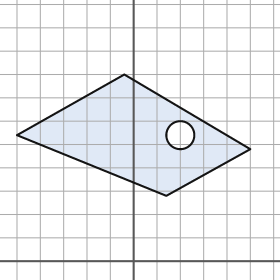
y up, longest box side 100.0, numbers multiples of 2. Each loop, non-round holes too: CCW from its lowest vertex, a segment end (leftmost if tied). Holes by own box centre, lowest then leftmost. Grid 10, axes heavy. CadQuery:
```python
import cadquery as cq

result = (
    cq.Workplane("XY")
    .moveTo(14.0, 28.0)
    .lineTo(50.0, 48.0)
    .lineTo(-4.0, 80.0)
    .lineTo(-50.0, 54.0)
    .close()
    .moveTo(20.0, 54.0)
    .circle(6.0)
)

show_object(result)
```